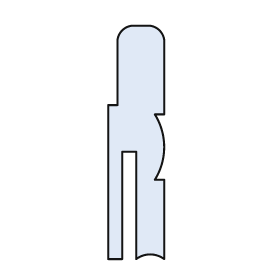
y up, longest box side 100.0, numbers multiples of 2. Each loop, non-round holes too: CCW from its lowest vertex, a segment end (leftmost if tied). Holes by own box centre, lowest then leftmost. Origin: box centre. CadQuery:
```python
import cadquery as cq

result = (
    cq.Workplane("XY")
    .moveTo(-12.0, -50.0)
    .lineTo(-6.0, -50.0)
    .lineTo(-6.0, -4.0)
    .lineTo(0.0, -4.0)
    .lineTo(0.0, -50.0)
    .threePointArc((6.0, -48.0), (12.0, -50.0))
    .lineTo(12.0, -16.0)
    .lineTo(8.0, -16.0)
    .threePointArc((12.0, -2.0), (8.0, 12.0))
    .lineTo(12.0, 12.0)
    .lineTo(12.0, 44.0)
    .threePointArc((10.0, 48.0), (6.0, 50.0))
    .lineTo(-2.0, 50.0)
    .threePointArc((-6.0, 48.0), (-8.0, 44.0))
    .lineTo(-8.0, 16.0)
    .lineTo(-12.0, 16.0)
    .close()
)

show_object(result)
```